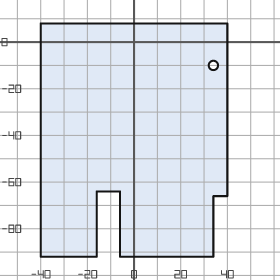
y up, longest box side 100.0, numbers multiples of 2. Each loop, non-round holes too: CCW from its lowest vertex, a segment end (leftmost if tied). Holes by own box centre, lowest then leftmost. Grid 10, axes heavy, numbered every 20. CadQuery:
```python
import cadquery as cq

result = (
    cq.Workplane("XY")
    .moveTo(-40.0, -92.0)
    .lineTo(-16.0, -92.0)
    .lineTo(-16.0, -64.0)
    .lineTo(-6.0, -64.0)
    .lineTo(-6.0, -92.0)
    .lineTo(34.0, -92.0)
    .lineTo(34.0, -66.0)
    .lineTo(40.0, -66.0)
    .lineTo(40.0, 8.0)
    .lineTo(-40.0, 8.0)
    .close()
    .moveTo(34.0, -10.0)
    .circle(2.0)
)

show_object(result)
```